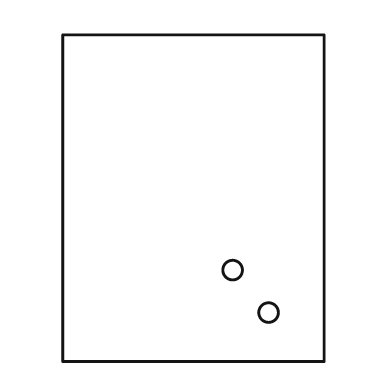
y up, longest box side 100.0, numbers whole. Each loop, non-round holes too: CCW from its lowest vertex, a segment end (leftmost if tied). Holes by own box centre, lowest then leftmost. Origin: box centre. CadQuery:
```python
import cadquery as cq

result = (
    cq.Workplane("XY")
    .moveTo(-40.0, -50.0)
    .lineTo(40.0, -50.0)
    .lineTo(40.0, 50.0)
    .lineTo(-40.0, 50.0)
    .close()
    .moveTo(23.0, -35.0)
    .circle(3.0)
    .moveTo(12.0, -22.0)
    .circle(3.0)
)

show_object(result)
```